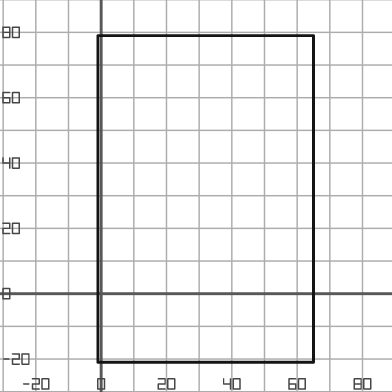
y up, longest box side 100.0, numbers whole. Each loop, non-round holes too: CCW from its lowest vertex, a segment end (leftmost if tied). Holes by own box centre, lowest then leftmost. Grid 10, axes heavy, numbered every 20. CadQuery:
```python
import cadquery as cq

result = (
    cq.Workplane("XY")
    .moveTo(-1.0, -21.0)
    .lineTo(65.0, -21.0)
    .lineTo(65.0, 79.0)
    .lineTo(-1.0, 79.0)
    .close()
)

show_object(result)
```